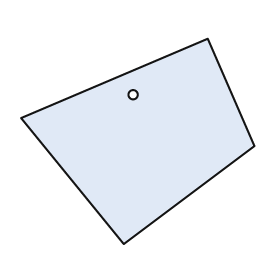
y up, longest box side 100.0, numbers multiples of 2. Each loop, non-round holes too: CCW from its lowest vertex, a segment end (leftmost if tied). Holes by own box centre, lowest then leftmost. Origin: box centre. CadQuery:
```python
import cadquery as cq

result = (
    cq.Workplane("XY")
    .moveTo(-6.0, -44.0)
    .lineTo(50.0, -2.0)
    .lineTo(30.0, 44.0)
    .lineTo(-50.0, 10.0)
    .close()
    .moveTo(-2.0, 20.0)
    .circle(2.0)
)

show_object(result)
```